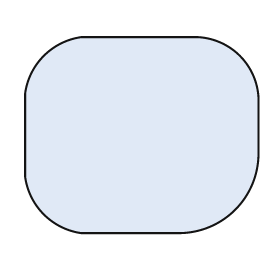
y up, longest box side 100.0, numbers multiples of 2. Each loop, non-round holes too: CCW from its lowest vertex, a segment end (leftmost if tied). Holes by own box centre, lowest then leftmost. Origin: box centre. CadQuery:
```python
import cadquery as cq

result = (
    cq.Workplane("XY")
    .moveTo(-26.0, -42.0)
    .lineTo(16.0, -42.0)
    .threePointArc((40.0, -32.0), (50.0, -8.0))
    .lineTo(50.0, 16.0)
    .threePointArc((42.0, 34.0), (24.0, 42.0))
    .lineTo(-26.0, 42.0)
    .threePointArc((-42.0, 34.0), (-50.0, 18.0))
    .lineTo(-50.0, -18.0)
    .threePointArc((-42.0, -34.0), (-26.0, -42.0))
    .close()
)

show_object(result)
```